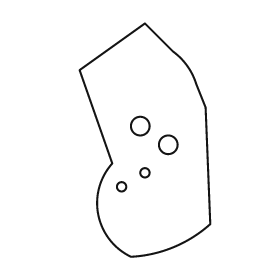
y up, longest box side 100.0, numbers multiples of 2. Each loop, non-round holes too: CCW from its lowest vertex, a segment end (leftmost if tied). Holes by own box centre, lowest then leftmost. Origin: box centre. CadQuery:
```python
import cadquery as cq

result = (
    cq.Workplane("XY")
    .moveTo(-6.0, -50.0)
    .threePointArc((12.0, -46.0), (28.0, -36.0))
    .lineTo(26.0, 14.0)
    .lineTo(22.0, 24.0)
    .threePointArc((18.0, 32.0), (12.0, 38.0))
    .lineTo(0.0, 50.0)
    .lineTo(-28.0, 30.0)
    .lineTo(-14.0, -10.0)
    .threePointArc((-20.0, -32.0), (-6.0, -50.0))
    .close()
    .moveTo(-10.0, -20.0)
    .circle(2.0)
    .moveTo(0.0, -14.0)
    .circle(2.0)
    .moveTo(10.0, -2.0)
    .circle(4.0)
    .moveTo(-2.0, 6.0)
    .circle(4.0)
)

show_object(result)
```